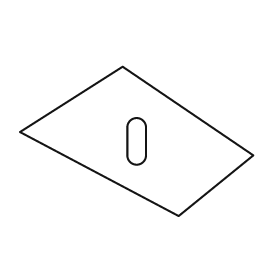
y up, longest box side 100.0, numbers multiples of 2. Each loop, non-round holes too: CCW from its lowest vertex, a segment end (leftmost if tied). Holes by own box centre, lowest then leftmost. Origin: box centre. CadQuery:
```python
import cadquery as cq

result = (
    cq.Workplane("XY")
    .moveTo(18.0, -32.0)
    .lineTo(50.0, -6.0)
    .lineTo(-6.0, 32.0)
    .lineTo(-50.0, 4.0)
    .close()
    .moveTo(-4.0, -6.0)
    .threePointArc((0.0, -10.0), (4.0, -6.0))
    .lineTo(4.0, 6.0)
    .threePointArc((0.0, 10.0), (-4.0, 6.0))
    .close()
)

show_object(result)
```